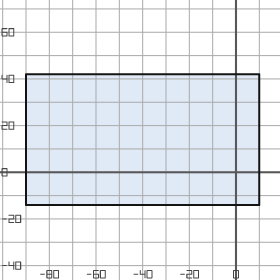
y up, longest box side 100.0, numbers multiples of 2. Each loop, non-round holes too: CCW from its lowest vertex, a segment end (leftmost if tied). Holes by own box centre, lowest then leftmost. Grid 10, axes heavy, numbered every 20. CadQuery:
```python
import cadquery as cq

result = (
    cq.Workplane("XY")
    .moveTo(-90.0, -14.0)
    .lineTo(10.0, -14.0)
    .lineTo(10.0, 42.0)
    .lineTo(-90.0, 42.0)
    .close()
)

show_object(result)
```